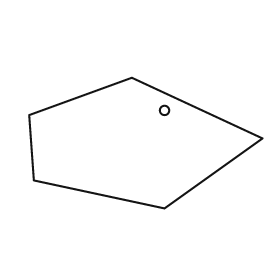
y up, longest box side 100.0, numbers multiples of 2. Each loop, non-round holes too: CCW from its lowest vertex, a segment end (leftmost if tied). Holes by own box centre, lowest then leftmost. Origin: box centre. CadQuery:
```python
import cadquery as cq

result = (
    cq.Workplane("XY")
    .moveTo(8.0, -28.0)
    .lineTo(50.0, 2.0)
    .lineTo(-6.0, 28.0)
    .lineTo(-50.0, 12.0)
    .lineTo(-48.0, -16.0)
    .close()
    .moveTo(8.0, 14.0)
    .circle(2.0)
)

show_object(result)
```